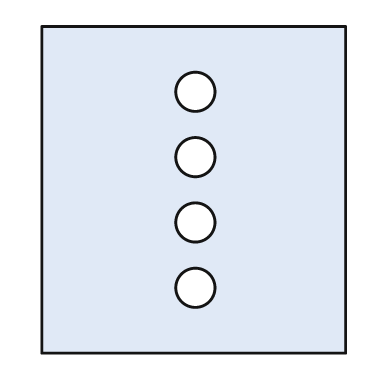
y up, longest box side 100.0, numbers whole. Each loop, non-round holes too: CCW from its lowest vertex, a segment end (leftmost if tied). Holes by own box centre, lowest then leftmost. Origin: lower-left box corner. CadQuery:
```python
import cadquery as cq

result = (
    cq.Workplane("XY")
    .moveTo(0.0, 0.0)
    .lineTo(93.0, 0.0)
    .lineTo(93.0, 100.0)
    .lineTo(0.0, 100.0)
    .close()
    .moveTo(47.0, 20.0)
    .circle(6.0)
    .moveTo(47.0, 40.0)
    .circle(6.0)
    .moveTo(47.0, 60.0)
    .circle(6.0)
    .moveTo(47.0, 80.0)
    .circle(6.0)
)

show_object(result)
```